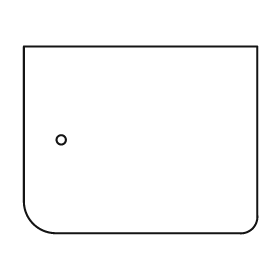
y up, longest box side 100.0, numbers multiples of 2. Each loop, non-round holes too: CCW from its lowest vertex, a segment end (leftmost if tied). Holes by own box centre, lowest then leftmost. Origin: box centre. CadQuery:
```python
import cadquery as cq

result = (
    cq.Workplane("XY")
    .moveTo(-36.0, -40.0)
    .lineTo(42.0, -40.0)
    .threePointArc((48.0, -38.0), (50.0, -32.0))
    .lineTo(50.0, 40.0)
    .lineTo(-50.0, 40.0)
    .lineTo(-50.0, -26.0)
    .threePointArc((-46.0, -36.0), (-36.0, -40.0))
    .close()
    .moveTo(-34.0, 0.0)
    .circle(2.0)
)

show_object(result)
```